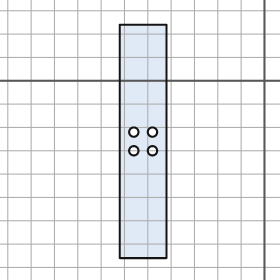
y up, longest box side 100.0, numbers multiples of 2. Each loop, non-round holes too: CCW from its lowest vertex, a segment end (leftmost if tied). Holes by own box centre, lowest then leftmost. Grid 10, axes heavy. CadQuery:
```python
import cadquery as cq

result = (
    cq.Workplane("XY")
    .moveTo(-62.0, -76.0)
    .lineTo(-42.0, -76.0)
    .lineTo(-42.0, 24.0)
    .lineTo(-62.0, 24.0)
    .close()
    .moveTo(-56.0, -30.0)
    .circle(2.0)
    .moveTo(-48.0, -30.0)
    .circle(2.0)
    .moveTo(-56.0, -22.0)
    .circle(2.0)
    .moveTo(-48.0, -22.0)
    .circle(2.0)
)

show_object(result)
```